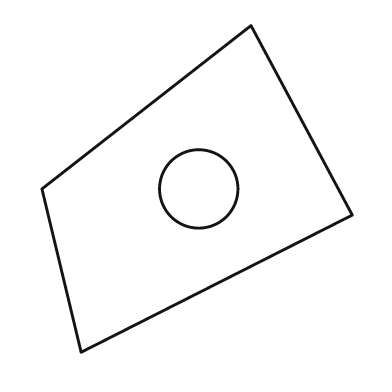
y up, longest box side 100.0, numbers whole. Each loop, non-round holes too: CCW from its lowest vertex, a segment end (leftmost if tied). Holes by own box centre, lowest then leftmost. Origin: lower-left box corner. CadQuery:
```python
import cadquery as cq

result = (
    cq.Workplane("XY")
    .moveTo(12.0, 0.0)
    .lineTo(95.0, 42.0)
    .lineTo(64.0, 100.0)
    .lineTo(0.0, 50.0)
    .close()
    .moveTo(48.0, 50.0)
    .circle(12.0)
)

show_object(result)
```